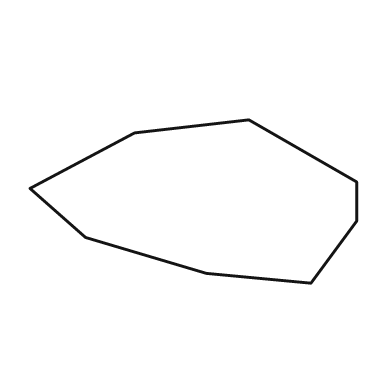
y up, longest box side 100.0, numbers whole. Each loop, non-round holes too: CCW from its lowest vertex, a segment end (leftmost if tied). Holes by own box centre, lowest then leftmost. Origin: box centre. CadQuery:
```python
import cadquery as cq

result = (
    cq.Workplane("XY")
    .moveTo(36.0, -25.0)
    .lineTo(50.0, -6.0)
    .lineTo(50.0, 6.0)
    .lineTo(17.0, 25.0)
    .lineTo(-18.0, 21.0)
    .lineTo(-50.0, 4.0)
    .lineTo(-33.0, -11.0)
    .lineTo(4.0, -22.0)
    .close()
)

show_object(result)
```